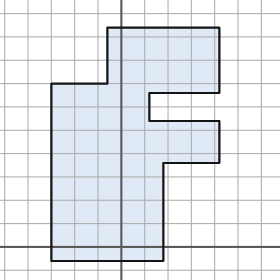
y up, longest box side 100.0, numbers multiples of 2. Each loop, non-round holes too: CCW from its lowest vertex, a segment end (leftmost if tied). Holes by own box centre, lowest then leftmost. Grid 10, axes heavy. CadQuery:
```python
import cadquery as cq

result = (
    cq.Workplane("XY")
    .moveTo(-30.0, -6.0)
    .lineTo(18.0, -6.0)
    .lineTo(18.0, 36.0)
    .lineTo(42.0, 36.0)
    .lineTo(42.0, 54.0)
    .lineTo(12.0, 54.0)
    .lineTo(12.0, 66.0)
    .lineTo(42.0, 66.0)
    .lineTo(42.0, 94.0)
    .lineTo(-6.0, 94.0)
    .lineTo(-6.0, 70.0)
    .lineTo(-30.0, 70.0)
    .close()
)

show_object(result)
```